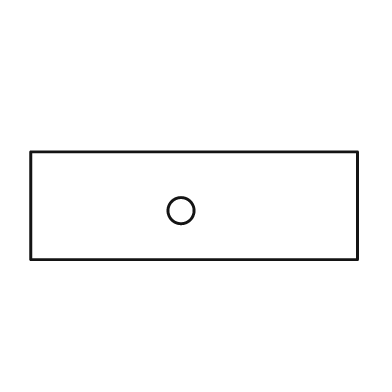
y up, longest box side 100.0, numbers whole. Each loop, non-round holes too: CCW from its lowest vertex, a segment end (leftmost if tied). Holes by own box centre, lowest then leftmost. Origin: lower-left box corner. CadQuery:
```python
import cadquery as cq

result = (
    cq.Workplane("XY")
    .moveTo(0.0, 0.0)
    .lineTo(100.0, 0.0)
    .lineTo(100.0, 33.0)
    .lineTo(0.0, 33.0)
    .close()
    .moveTo(46.0, 15.0)
    .circle(4.0)
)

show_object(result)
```